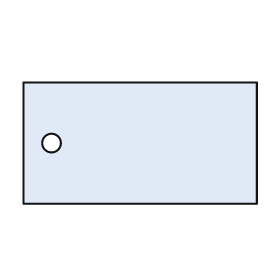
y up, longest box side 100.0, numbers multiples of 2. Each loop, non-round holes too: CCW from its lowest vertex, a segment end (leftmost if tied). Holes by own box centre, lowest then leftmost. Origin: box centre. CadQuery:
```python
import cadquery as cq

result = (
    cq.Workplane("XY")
    .moveTo(-50.0, -26.0)
    .lineTo(50.0, -26.0)
    .lineTo(50.0, 26.0)
    .lineTo(-50.0, 26.0)
    .close()
    .moveTo(-38.0, 0.0)
    .circle(4.0)
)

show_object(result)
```